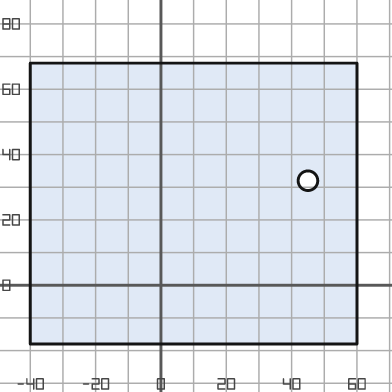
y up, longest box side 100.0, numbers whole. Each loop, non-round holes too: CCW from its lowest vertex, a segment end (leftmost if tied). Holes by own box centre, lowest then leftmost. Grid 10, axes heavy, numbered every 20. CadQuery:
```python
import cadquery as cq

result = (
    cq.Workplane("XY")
    .moveTo(-40.0, -18.0)
    .lineTo(60.0, -18.0)
    .lineTo(60.0, 68.0)
    .lineTo(-40.0, 68.0)
    .close()
    .moveTo(45.0, 32.0)
    .circle(3.0)
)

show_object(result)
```